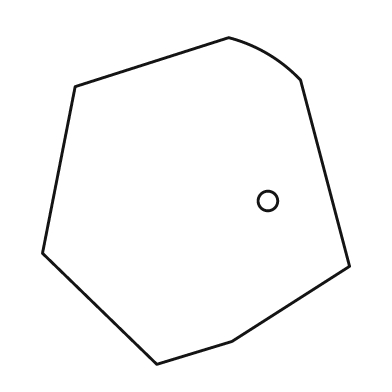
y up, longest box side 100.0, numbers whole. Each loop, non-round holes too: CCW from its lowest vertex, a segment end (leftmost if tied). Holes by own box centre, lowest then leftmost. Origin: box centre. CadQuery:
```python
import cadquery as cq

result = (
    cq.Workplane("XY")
    .moveTo(-12.0, -50.0)
    .lineTo(11.0, -43.0)
    .lineTo(47.0, -20.0)
    .lineTo(32.0, 37.0)
    .threePointArc((22.0, 45.0), (10.0, 50.0))
    .lineTo(-37.0, 35.0)
    .lineTo(-47.0, -16.0)
    .close()
    .moveTo(22.0, 0.0)
    .circle(3.0)
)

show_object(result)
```